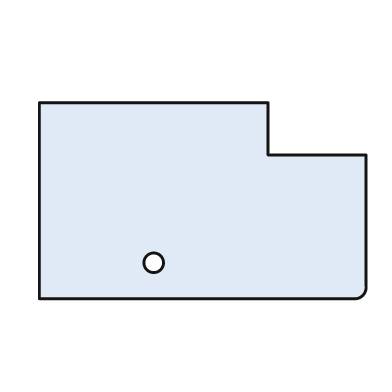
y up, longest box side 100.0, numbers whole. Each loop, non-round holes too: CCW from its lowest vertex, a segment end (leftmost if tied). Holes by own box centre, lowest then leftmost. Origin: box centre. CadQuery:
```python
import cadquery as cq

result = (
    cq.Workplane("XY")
    .moveTo(-50.0, -30.0)
    .lineTo(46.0, -30.0)
    .threePointArc((49.0, -29.0), (50.0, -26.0))
    .lineTo(50.0, 14.0)
    .lineTo(20.0, 14.0)
    .lineTo(20.0, 30.0)
    .lineTo(-50.0, 30.0)
    .close()
    .moveTo(-15.0, -19.0)
    .circle(3.0)
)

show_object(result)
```